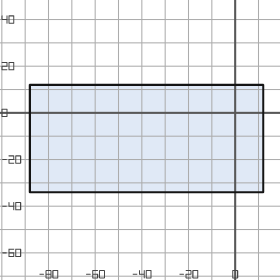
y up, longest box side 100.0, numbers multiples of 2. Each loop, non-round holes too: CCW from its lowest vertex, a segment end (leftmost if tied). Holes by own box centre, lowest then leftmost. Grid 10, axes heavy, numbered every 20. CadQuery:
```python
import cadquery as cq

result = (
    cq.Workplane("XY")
    .moveTo(-88.0, -34.0)
    .lineTo(12.0, -34.0)
    .lineTo(12.0, 12.0)
    .lineTo(-88.0, 12.0)
    .close()
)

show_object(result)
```